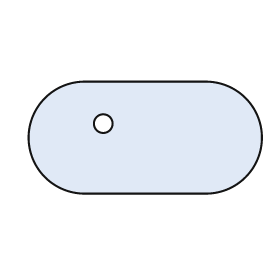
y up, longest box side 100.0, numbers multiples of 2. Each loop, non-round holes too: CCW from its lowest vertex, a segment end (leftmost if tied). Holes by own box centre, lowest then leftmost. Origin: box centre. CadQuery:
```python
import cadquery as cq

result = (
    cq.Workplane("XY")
    .moveTo(-26.0, -24.0)
    .lineTo(26.0, -24.0)
    .threePointArc((50.0, 0.0), (26.0, 24.0))
    .lineTo(-26.0, 24.0)
    .threePointArc((-50.0, 0.0), (-26.0, -24.0))
    .close()
    .moveTo(-18.0, 6.0)
    .circle(4.0)
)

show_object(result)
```